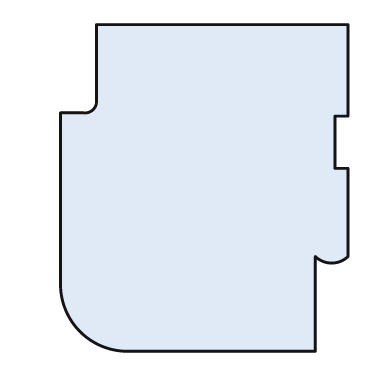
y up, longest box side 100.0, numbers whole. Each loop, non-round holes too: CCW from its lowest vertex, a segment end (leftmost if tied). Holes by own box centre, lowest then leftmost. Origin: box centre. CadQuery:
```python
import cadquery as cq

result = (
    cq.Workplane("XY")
    .moveTo(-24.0, -50.0)
    .lineTo(34.0, -50.0)
    .lineTo(34.0, -21.0)
    .threePointArc((39.0, -23.0), (44.0, -21.0))
    .lineTo(44.0, 6.0)
    .lineTo(40.0, 6.0)
    .lineTo(40.0, 22.0)
    .lineTo(44.0, 22.0)
    .lineTo(44.0, 50.0)
    .lineTo(-33.0, 50.0)
    .lineTo(-33.0, 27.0)
    .threePointArc((-34.0, 24.0), (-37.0, 23.0))
    .lineTo(-44.0, 23.0)
    .lineTo(-44.0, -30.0)
    .threePointArc((-38.0, -44.0), (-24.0, -50.0))
    .close()
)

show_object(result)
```